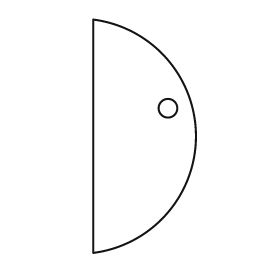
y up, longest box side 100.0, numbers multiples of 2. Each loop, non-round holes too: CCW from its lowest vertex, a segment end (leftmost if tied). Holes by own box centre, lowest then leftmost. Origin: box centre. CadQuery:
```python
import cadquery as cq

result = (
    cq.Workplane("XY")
    .moveTo(-22.0, -50.0)
    .threePointArc((22.0, 0.0), (-22.0, 50.0))
    .close()
    .moveTo(10.0, 12.0)
    .circle(4.0)
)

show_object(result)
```